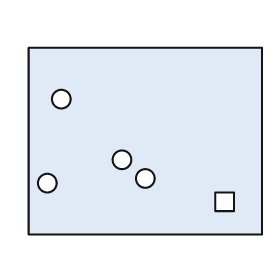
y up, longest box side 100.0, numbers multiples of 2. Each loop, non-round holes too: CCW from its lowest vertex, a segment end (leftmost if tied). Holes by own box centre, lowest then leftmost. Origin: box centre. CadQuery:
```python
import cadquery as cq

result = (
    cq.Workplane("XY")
    .moveTo(-50.0, -40.0)
    .lineTo(50.0, -40.0)
    .lineTo(50.0, 40.0)
    .lineTo(-50.0, 40.0)
    .close()
    .moveTo(30.0, -30.0)
    .lineTo(38.0, -30.0)
    .lineTo(38.0, -22.0)
    .lineTo(30.0, -22.0)
    .close()
    .moveTo(-42.0, -18.0)
    .circle(4.0)
    .moveTo(0.0, -16.0)
    .circle(4.0)
    .moveTo(-10.0, -8.0)
    .circle(4.0)
    .moveTo(-36.0, 18.0)
    .circle(4.0)
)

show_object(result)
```